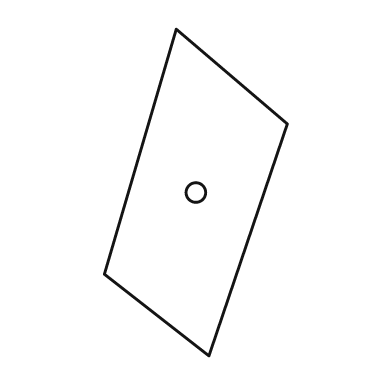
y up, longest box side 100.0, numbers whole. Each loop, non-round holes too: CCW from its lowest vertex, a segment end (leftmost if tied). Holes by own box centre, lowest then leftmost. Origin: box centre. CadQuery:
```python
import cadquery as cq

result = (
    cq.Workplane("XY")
    .moveTo(4.0, -50.0)
    .lineTo(28.0, 21.0)
    .lineTo(-6.0, 50.0)
    .lineTo(-28.0, -25.0)
    .close()
    .moveTo(0.0, 0.0)
    .circle(3.0)
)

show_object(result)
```